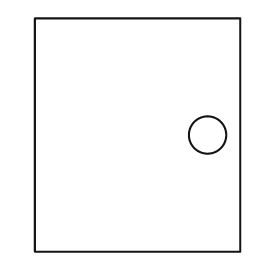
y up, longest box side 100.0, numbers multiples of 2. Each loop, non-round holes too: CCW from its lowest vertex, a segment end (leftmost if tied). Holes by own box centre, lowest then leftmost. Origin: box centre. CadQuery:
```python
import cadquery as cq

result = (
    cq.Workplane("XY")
    .moveTo(-44.0, -50.0)
    .lineTo(44.0, -50.0)
    .lineTo(44.0, 50.0)
    .lineTo(-44.0, 50.0)
    .close()
    .moveTo(30.0, 0.0)
    .circle(8.0)
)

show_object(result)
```